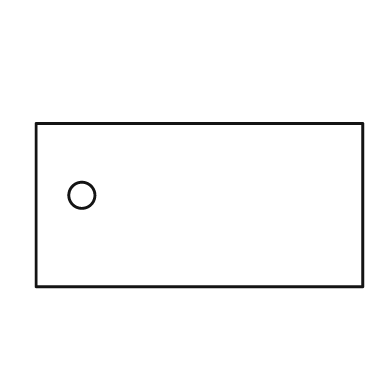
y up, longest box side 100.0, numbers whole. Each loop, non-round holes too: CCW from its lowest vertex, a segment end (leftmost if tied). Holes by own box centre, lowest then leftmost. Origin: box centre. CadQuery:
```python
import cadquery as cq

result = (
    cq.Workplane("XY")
    .moveTo(-50.0, -25.0)
    .lineTo(50.0, -25.0)
    .lineTo(50.0, 25.0)
    .lineTo(-50.0, 25.0)
    .close()
    .moveTo(-36.0, 3.0)
    .circle(4.0)
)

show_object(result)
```